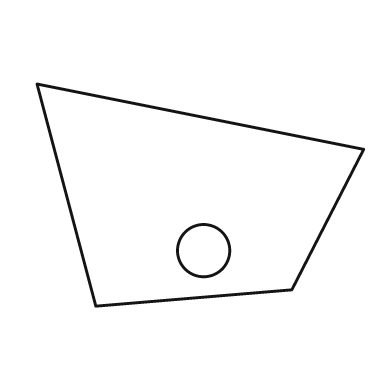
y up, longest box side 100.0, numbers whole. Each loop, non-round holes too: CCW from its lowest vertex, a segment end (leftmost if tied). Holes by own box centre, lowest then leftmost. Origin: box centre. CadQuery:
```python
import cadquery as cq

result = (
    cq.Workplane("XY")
    .moveTo(-32.0, -34.0)
    .lineTo(28.0, -29.0)
    .lineTo(50.0, 14.0)
    .lineTo(-50.0, 34.0)
    .close()
    .moveTo(1.0, -17.0)
    .circle(8.0)
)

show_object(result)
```